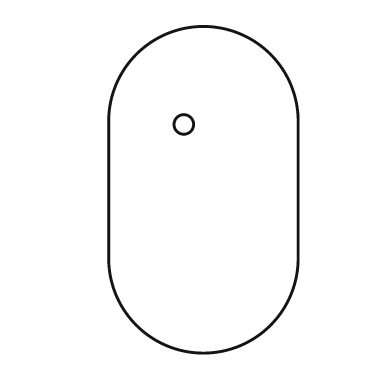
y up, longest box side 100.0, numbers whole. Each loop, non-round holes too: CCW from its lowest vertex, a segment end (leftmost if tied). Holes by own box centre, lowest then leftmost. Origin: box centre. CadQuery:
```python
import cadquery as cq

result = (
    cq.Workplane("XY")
    .moveTo(-29.0, -21.0)
    .threePointArc((0.0, -50.0), (29.0, -21.0))
    .lineTo(29.0, 21.0)
    .threePointArc((0.0, 50.0), (-29.0, 21.0))
    .close()
    .moveTo(-6.0, 20.0)
    .circle(3.0)
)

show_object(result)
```